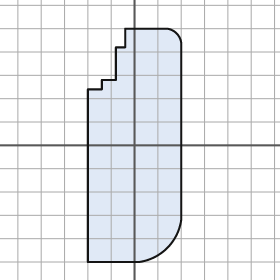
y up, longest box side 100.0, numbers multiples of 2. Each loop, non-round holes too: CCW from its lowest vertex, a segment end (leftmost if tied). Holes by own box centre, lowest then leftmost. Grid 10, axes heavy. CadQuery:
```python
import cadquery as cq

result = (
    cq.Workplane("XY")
    .moveTo(-20.0, -50.0)
    .lineTo(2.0, -50.0)
    .threePointArc((14.0, -44.0), (20.0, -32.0))
    .lineTo(20.0, 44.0)
    .threePointArc((18.0, 48.0), (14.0, 50.0))
    .lineTo(-4.0, 50.0)
    .lineTo(-4.0, 42.0)
    .lineTo(-8.0, 42.0)
    .lineTo(-8.0, 28.0)
    .lineTo(-14.0, 28.0)
    .lineTo(-14.0, 24.0)
    .lineTo(-20.0, 24.0)
    .close()
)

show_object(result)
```